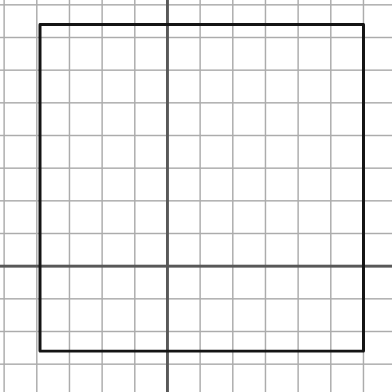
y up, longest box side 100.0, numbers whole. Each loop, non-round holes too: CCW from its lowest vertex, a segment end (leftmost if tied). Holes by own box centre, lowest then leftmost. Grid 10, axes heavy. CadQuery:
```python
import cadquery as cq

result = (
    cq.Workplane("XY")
    .moveTo(-39.0, -26.0)
    .lineTo(60.0, -26.0)
    .lineTo(60.0, 74.0)
    .lineTo(-39.0, 74.0)
    .close()
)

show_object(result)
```